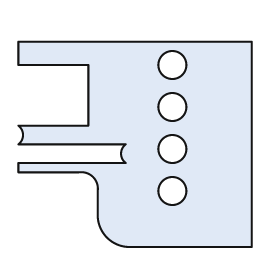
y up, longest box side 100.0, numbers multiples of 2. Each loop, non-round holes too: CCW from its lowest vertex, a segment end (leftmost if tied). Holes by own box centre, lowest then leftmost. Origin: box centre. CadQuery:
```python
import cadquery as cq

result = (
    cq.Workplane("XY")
    .moveTo(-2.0, -44.0)
    .lineTo(50.0, -44.0)
    .lineTo(50.0, 44.0)
    .lineTo(-50.0, 44.0)
    .lineTo(-50.0, 34.0)
    .lineTo(-20.0, 34.0)
    .lineTo(-20.0, 8.0)
    .lineTo(-50.0, 8.0)
    .threePointArc((-48.0, 4.0), (-50.0, 0.0))
    .lineTo(-4.0, 0.0)
    .threePointArc((-6.0, -4.0), (-4.0, -8.0))
    .lineTo(-50.0, -8.0)
    .lineTo(-50.0, -12.0)
    .lineTo(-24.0, -12.0)
    .threePointArc((-18.0, -14.0), (-16.0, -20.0))
    .lineTo(-16.0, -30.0)
    .threePointArc((-12.0, -40.0), (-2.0, -44.0))
    .close()
    .moveTo(16.0, -20.0)
    .circle(6.0)
    .moveTo(16.0, -2.0)
    .circle(6.0)
    .moveTo(16.0, 16.0)
    .circle(6.0)
    .moveTo(16.0, 34.0)
    .circle(6.0)
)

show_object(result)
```